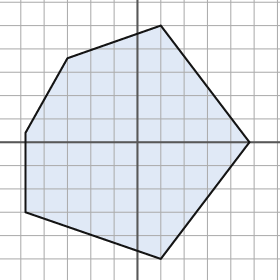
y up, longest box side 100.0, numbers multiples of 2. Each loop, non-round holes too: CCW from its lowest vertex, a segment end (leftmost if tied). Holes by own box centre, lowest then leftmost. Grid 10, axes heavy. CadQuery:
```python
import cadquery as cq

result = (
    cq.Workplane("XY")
    .moveTo(10.0, -50.0)
    .lineTo(48.0, 0.0)
    .lineTo(10.0, 50.0)
    .lineTo(-30.0, 36.0)
    .lineTo(-48.0, 4.0)
    .lineTo(-48.0, -30.0)
    .close()
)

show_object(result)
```